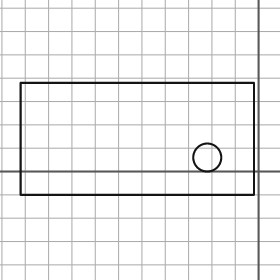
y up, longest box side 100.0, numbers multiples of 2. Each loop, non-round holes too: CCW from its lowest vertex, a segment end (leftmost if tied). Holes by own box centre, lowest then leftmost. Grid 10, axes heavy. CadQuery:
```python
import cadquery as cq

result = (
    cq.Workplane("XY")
    .moveTo(-102.0, -10.0)
    .lineTo(-2.0, -10.0)
    .lineTo(-2.0, 38.0)
    .lineTo(-102.0, 38.0)
    .close()
    .moveTo(-22.0, 6.0)
    .circle(6.0)
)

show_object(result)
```